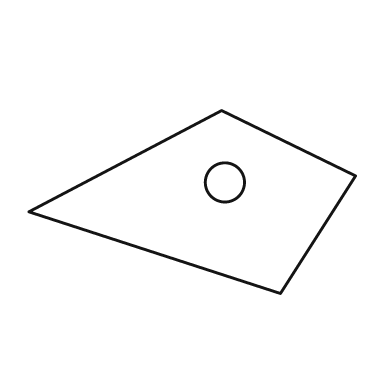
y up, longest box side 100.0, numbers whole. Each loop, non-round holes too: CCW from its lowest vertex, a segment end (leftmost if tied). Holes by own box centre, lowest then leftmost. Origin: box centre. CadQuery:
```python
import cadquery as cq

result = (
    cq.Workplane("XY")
    .moveTo(27.0, -28.0)
    .lineTo(50.0, 8.0)
    .lineTo(9.0, 28.0)
    .lineTo(-50.0, -3.0)
    .close()
    .moveTo(10.0, 6.0)
    .circle(6.0)
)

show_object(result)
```